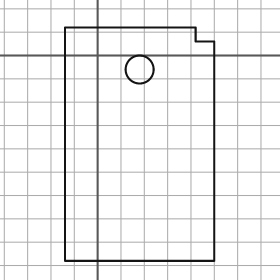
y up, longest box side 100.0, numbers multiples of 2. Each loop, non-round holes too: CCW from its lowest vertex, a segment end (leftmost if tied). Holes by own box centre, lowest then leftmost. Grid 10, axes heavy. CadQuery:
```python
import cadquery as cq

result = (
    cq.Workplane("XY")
    .moveTo(-14.0, -88.0)
    .lineTo(50.0, -88.0)
    .lineTo(50.0, 6.0)
    .lineTo(42.0, 6.0)
    .lineTo(42.0, 12.0)
    .lineTo(-14.0, 12.0)
    .close()
    .moveTo(18.0, -6.0)
    .circle(6.0)
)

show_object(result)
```